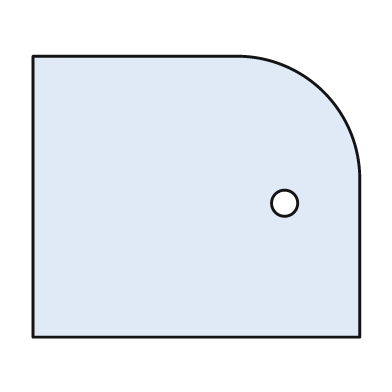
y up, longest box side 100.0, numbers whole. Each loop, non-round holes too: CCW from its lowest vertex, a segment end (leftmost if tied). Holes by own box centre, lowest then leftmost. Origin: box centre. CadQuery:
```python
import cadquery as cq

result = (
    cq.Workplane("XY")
    .moveTo(-50.0, -43.0)
    .lineTo(50.0, -43.0)
    .lineTo(50.0, 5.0)
    .threePointArc((39.0, 32.0), (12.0, 43.0))
    .lineTo(-50.0, 43.0)
    .close()
    .moveTo(27.0, -2.0)
    .circle(4.0)
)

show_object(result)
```